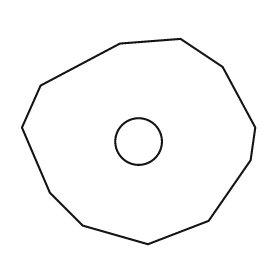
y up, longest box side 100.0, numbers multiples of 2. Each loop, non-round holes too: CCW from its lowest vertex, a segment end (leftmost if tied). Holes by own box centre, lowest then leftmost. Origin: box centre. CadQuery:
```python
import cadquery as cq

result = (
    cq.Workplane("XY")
    .moveTo(4.0, -44.0)
    .lineTo(30.0, -34.0)
    .lineTo(48.0, -8.0)
    .lineTo(50.0, 6.0)
    .lineTo(36.0, 32.0)
    .lineTo(18.0, 44.0)
    .lineTo(-8.0, 42.0)
    .lineTo(-42.0, 24.0)
    .lineTo(-50.0, 6.0)
    .lineTo(-38.0, -22.0)
    .lineTo(-24.0, -36.0)
    .close()
    .moveTo(0.0, 0.0)
    .circle(10.0)
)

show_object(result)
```